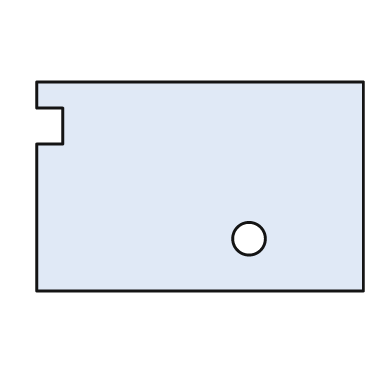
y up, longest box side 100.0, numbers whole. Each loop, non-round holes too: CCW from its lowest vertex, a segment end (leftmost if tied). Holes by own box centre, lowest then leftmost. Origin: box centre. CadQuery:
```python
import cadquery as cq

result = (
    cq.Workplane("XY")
    .moveTo(-50.0, -32.0)
    .lineTo(50.0, -32.0)
    .lineTo(50.0, 32.0)
    .lineTo(-50.0, 32.0)
    .lineTo(-50.0, 24.0)
    .lineTo(-42.0, 24.0)
    .lineTo(-42.0, 13.0)
    .lineTo(-50.0, 13.0)
    .close()
    .moveTo(15.0, -16.0)
    .circle(5.0)
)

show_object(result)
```